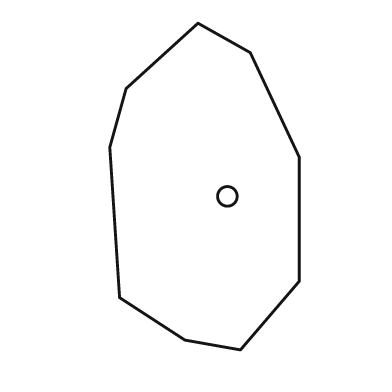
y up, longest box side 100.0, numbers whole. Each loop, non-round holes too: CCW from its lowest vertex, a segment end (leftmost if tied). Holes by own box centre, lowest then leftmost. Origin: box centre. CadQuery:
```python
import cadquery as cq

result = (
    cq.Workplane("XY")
    .moveTo(11.0, -50.0)
    .lineTo(29.0, -29.0)
    .lineTo(29.0, 9.0)
    .lineTo(14.0, 41.0)
    .lineTo(-2.0, 50.0)
    .lineTo(-24.0, 30.0)
    .lineTo(-29.0, 12.0)
    .lineTo(-26.0, -34.0)
    .lineTo(-6.0, -47.0)
    .close()
    .moveTo(7.0, -3.0)
    .circle(3.0)
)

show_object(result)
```